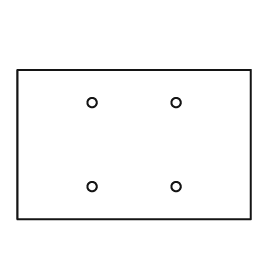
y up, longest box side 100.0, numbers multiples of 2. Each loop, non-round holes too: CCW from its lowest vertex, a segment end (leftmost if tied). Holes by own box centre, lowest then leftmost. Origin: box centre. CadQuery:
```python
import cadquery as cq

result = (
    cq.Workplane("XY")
    .moveTo(-50.0, -32.0)
    .lineTo(50.0, -32.0)
    .lineTo(50.0, 32.0)
    .lineTo(-50.0, 32.0)
    .close()
    .moveTo(-18.0, -18.0)
    .circle(2.0)
    .moveTo(18.0, -18.0)
    .circle(2.0)
    .moveTo(-18.0, 18.0)
    .circle(2.0)
    .moveTo(18.0, 18.0)
    .circle(2.0)
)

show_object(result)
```